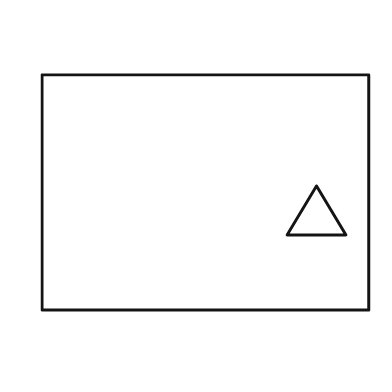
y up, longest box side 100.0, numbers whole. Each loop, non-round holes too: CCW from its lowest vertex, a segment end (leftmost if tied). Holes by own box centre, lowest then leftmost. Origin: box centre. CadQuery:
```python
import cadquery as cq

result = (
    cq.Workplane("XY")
    .moveTo(-50.0, -36.0)
    .lineTo(50.0, -36.0)
    .lineTo(50.0, 36.0)
    .lineTo(-50.0, 36.0)
    .close()
    .moveTo(25.0, -13.0)
    .lineTo(43.0, -13.0)
    .lineTo(34.0, 2.0)
    .close()
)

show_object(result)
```